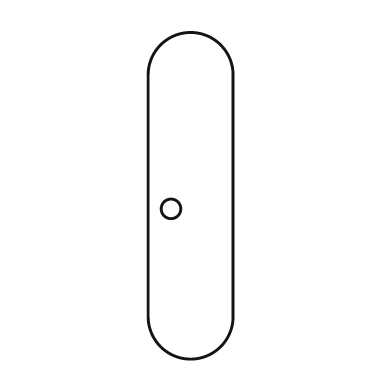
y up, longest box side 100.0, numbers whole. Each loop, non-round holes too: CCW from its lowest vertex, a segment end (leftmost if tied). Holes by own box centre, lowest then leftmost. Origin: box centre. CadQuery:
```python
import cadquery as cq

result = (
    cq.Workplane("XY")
    .moveTo(-13.0, -37.0)
    .threePointArc((0.0, -50.0), (13.0, -37.0))
    .lineTo(13.0, 37.0)
    .threePointArc((0.0, 50.0), (-13.0, 37.0))
    .close()
    .moveTo(-6.0, -4.0)
    .circle(3.0)
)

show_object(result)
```